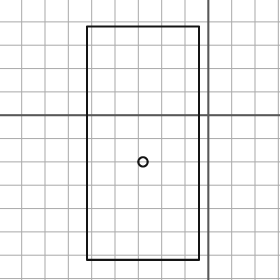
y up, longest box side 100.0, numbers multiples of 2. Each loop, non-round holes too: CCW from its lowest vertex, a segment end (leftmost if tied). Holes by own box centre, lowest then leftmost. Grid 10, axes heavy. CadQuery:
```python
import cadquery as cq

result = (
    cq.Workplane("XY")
    .moveTo(-52.0, -62.0)
    .lineTo(-4.0, -62.0)
    .lineTo(-4.0, 38.0)
    .lineTo(-52.0, 38.0)
    .close()
    .moveTo(-28.0, -20.0)
    .circle(2.0)
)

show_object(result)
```